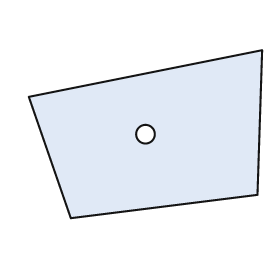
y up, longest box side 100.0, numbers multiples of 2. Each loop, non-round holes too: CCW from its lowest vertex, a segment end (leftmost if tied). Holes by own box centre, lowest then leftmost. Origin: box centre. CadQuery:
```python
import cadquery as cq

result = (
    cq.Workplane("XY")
    .moveTo(-32.0, -36.0)
    .lineTo(48.0, -26.0)
    .lineTo(50.0, 36.0)
    .lineTo(-50.0, 16.0)
    .close()
    .moveTo(0.0, 0.0)
    .circle(4.0)
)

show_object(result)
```